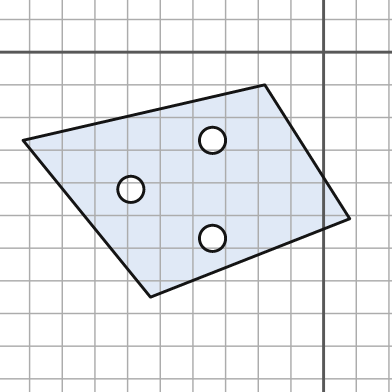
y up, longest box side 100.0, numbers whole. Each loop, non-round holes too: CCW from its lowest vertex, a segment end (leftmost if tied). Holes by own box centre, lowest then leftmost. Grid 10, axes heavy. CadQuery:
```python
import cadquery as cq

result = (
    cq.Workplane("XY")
    .moveTo(-53.0, -75.0)
    .lineTo(8.0, -51.0)
    .lineTo(-18.0, -10.0)
    .lineTo(-92.0, -27.0)
    .close()
    .moveTo(-34.0, -57.0)
    .circle(4.0)
    .moveTo(-59.0, -42.0)
    .circle(4.0)
    .moveTo(-34.0, -27.0)
    .circle(4.0)
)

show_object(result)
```